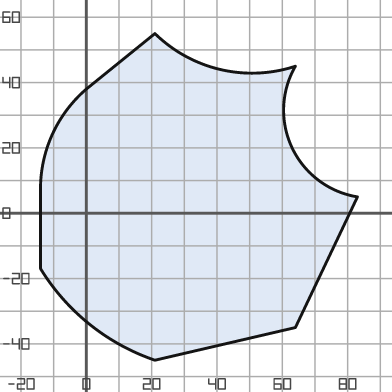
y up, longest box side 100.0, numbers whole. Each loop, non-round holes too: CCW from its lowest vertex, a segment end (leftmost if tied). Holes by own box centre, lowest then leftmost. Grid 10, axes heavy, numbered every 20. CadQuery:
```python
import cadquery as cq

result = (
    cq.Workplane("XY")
    .moveTo(21.0, -45.0)
    .lineTo(64.0, -35.0)
    .lineTo(83.0, 5.0)
    .threePointArc((63.0, 20.0), (64.0, 45.0))
    .threePointArc((41.0, 44.0), (21.0, 55.0))
    .lineTo(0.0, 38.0)
    .threePointArc((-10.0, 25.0), (-14.0, 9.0))
    .lineTo(-14.0, -17.0)
    .threePointArc((1.0, -34.0), (21.0, -45.0))
    .close()
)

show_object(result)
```